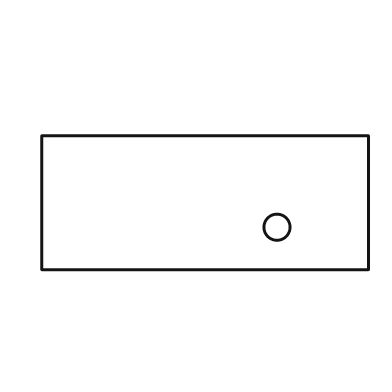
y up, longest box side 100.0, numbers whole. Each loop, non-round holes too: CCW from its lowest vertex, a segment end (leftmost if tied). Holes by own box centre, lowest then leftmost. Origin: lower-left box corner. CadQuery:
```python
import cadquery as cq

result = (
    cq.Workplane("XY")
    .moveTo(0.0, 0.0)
    .lineTo(100.0, 0.0)
    .lineTo(100.0, 41.0)
    .lineTo(0.0, 41.0)
    .close()
    .moveTo(72.0, 13.0)
    .circle(4.0)
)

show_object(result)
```